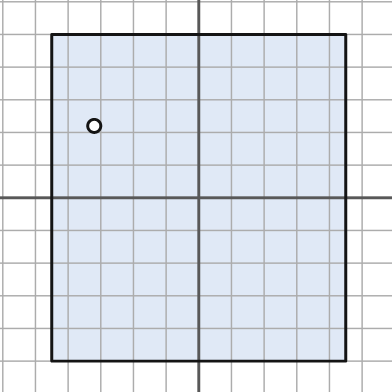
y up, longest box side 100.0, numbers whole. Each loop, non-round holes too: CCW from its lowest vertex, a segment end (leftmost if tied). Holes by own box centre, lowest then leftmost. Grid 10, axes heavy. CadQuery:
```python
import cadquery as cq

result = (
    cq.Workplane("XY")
    .moveTo(-45.0, -50.0)
    .lineTo(45.0, -50.0)
    .lineTo(45.0, 50.0)
    .lineTo(-45.0, 50.0)
    .close()
    .moveTo(-32.0, 22.0)
    .circle(2.0)
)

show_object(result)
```